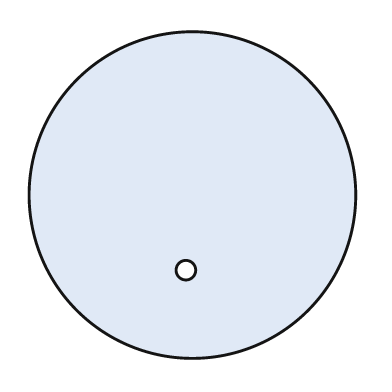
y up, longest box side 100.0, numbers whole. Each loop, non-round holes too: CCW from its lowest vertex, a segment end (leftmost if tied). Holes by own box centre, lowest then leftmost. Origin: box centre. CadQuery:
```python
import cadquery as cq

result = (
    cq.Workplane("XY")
    .moveTo(0.0, 0.0)
    .circle(50.0)
    .moveTo(-2.0, -23.0)
    .circle(3.0)
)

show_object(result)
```